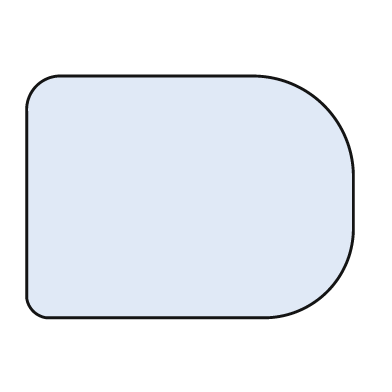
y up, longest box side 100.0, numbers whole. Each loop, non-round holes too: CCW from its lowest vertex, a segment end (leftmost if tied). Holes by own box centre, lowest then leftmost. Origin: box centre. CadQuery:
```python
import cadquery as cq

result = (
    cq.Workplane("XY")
    .moveTo(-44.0, -37.0)
    .lineTo(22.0, -37.0)
    .threePointArc((42.0, -29.0), (50.0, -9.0))
    .lineTo(50.0, 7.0)
    .threePointArc((41.0, 28.0), (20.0, 37.0))
    .lineTo(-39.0, 37.0)
    .threePointArc((-47.0, 34.0), (-50.0, 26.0))
    .lineTo(-50.0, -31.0)
    .threePointArc((-48.0, -35.0), (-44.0, -37.0))
    .close()
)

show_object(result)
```